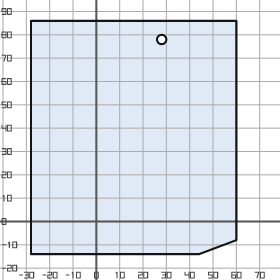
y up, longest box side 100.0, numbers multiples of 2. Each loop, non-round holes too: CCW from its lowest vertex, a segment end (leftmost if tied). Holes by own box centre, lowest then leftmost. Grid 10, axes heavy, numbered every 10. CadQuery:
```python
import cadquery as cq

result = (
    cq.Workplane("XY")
    .moveTo(-28.0, -14.0)
    .lineTo(44.0, -14.0)
    .lineTo(60.0, -8.0)
    .lineTo(60.0, 86.0)
    .lineTo(-28.0, 86.0)
    .close()
    .moveTo(28.0, 78.0)
    .circle(2.0)
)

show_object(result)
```